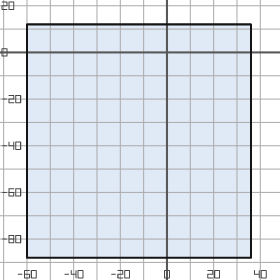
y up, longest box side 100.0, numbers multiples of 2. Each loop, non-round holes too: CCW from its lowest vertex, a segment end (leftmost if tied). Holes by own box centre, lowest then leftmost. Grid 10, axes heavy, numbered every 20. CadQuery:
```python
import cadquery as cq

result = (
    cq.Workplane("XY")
    .moveTo(-60.0, -88.0)
    .lineTo(36.0, -88.0)
    .lineTo(36.0, 12.0)
    .lineTo(-60.0, 12.0)
    .close()
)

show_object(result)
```